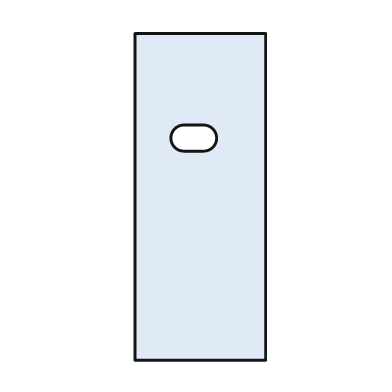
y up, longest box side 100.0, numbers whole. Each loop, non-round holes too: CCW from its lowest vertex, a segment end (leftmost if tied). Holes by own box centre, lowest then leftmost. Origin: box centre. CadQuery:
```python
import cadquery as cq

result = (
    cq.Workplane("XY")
    .moveTo(-20.0, -50.0)
    .lineTo(20.0, -50.0)
    .lineTo(20.0, 50.0)
    .lineTo(-20.0, 50.0)
    .close()
    .moveTo(-5.0, 14.0)
    .lineTo(1.0, 14.0)
    .threePointArc((5.0, 18.0), (1.0, 22.0))
    .lineTo(-5.0, 22.0)
    .threePointArc((-9.0, 18.0), (-5.0, 14.0))
    .close()
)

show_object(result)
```